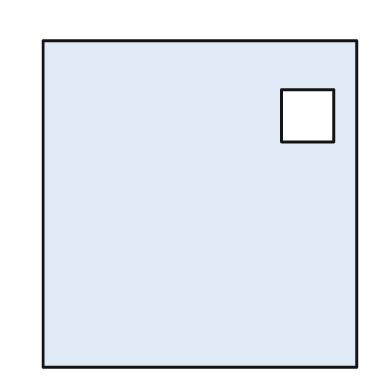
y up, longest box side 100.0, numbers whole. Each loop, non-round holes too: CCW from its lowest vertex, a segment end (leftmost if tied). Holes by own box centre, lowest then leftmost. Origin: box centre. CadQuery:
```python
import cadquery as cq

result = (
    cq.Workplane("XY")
    .moveTo(-48.0, -50.0)
    .lineTo(48.0, -50.0)
    .lineTo(48.0, 50.0)
    .lineTo(-48.0, 50.0)
    .close()
    .moveTo(25.0, 19.0)
    .lineTo(41.0, 19.0)
    .lineTo(41.0, 35.0)
    .lineTo(25.0, 35.0)
    .close()
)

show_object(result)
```